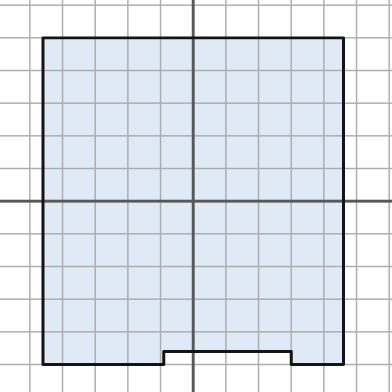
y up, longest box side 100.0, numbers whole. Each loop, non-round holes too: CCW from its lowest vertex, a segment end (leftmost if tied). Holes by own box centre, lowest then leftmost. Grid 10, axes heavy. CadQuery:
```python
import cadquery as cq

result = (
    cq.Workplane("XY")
    .moveTo(-46.0, -50.0)
    .lineTo(-9.0, -50.0)
    .lineTo(-9.0, -46.0)
    .lineTo(30.0, -46.0)
    .lineTo(30.0, -50.0)
    .lineTo(46.0, -50.0)
    .lineTo(46.0, 50.0)
    .lineTo(-46.0, 50.0)
    .close()
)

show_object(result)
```